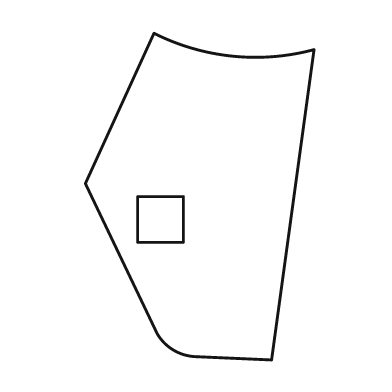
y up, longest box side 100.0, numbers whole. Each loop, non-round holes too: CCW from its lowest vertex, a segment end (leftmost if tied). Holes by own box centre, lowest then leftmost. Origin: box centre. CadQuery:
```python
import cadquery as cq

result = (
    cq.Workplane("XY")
    .moveTo(22.0, -50.0)
    .lineTo(35.0, 45.0)
    .threePointArc((10.0, 43.0), (-14.0, 50.0))
    .lineTo(-35.0, 4.0)
    .lineTo(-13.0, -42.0)
    .threePointArc((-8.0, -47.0), (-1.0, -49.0))
    .close()
    .moveTo(-19.0, -14.0)
    .lineTo(-5.0, -14.0)
    .lineTo(-5.0, 0.0)
    .lineTo(-19.0, 0.0)
    .close()
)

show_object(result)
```